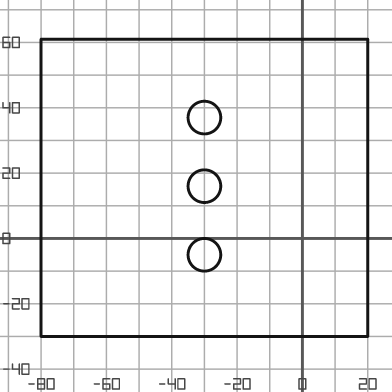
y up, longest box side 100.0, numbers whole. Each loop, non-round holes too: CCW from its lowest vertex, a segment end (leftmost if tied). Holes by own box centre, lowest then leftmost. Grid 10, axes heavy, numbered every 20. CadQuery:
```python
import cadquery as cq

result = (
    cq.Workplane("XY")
    .moveTo(-80.0, -30.0)
    .lineTo(20.0, -30.0)
    .lineTo(20.0, 61.0)
    .lineTo(-80.0, 61.0)
    .close()
    .moveTo(-30.0, -5.0)
    .circle(5.0)
    .moveTo(-30.0, 16.0)
    .circle(5.0)
    .moveTo(-30.0, 37.0)
    .circle(5.0)
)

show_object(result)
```